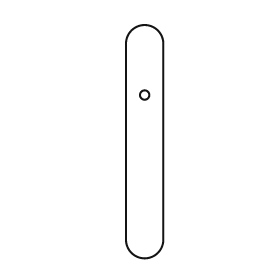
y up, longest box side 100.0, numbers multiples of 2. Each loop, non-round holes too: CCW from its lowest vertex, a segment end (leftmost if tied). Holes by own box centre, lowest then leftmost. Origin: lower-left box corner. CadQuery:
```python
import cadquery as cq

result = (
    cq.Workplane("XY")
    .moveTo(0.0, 8.0)
    .threePointArc((8.0, 0.0), (16.0, 8.0))
    .lineTo(16.0, 92.0)
    .threePointArc((8.0, 100.0), (0.0, 92.0))
    .close()
    .moveTo(8.0, 70.0)
    .circle(2.0)
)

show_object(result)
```